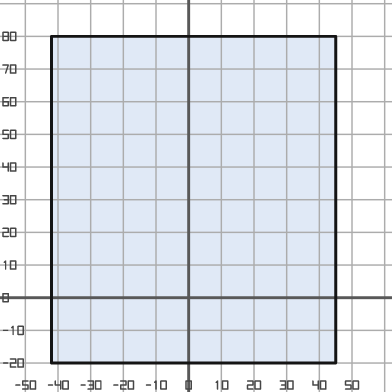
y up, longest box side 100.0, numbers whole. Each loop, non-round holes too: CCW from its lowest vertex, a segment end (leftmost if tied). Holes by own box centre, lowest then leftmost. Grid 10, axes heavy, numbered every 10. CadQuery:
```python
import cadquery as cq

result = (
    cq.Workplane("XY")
    .moveTo(-42.0, -20.0)
    .lineTo(45.0, -20.0)
    .lineTo(45.0, 80.0)
    .lineTo(-42.0, 80.0)
    .close()
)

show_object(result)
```